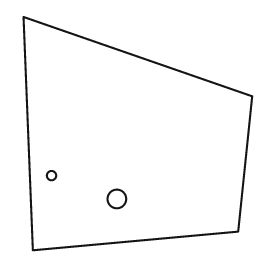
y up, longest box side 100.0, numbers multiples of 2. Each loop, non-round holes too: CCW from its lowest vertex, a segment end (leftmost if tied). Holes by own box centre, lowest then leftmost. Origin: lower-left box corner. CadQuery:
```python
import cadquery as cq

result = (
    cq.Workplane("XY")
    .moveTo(4.0, 0.0)
    .lineTo(92.0, 8.0)
    .lineTo(98.0, 66.0)
    .lineTo(0.0, 100.0)
    .close()
    .moveTo(40.0, 22.0)
    .circle(4.0)
    .moveTo(12.0, 32.0)
    .circle(2.0)
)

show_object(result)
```